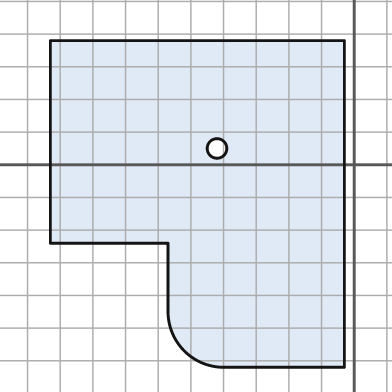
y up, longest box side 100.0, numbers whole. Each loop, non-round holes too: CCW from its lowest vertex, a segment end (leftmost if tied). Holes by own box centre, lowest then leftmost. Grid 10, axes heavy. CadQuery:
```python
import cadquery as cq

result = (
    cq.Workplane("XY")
    .moveTo(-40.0, -62.0)
    .lineTo(-3.0, -62.0)
    .lineTo(-3.0, 38.0)
    .lineTo(-93.0, 38.0)
    .lineTo(-93.0, -24.0)
    .lineTo(-57.0, -24.0)
    .lineTo(-57.0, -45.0)
    .threePointArc((-52.0, -57.0), (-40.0, -62.0))
    .close()
    .moveTo(-42.0, 5.0)
    .circle(3.0)
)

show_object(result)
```